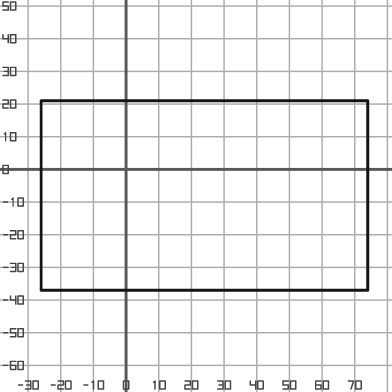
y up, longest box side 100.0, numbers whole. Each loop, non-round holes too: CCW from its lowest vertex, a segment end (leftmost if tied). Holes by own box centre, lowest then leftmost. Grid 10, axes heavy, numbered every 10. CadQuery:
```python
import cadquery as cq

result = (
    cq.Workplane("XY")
    .moveTo(-26.0, -37.0)
    .lineTo(74.0, -37.0)
    .lineTo(74.0, 21.0)
    .lineTo(-26.0, 21.0)
    .close()
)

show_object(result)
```